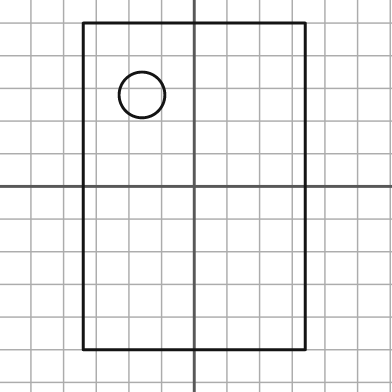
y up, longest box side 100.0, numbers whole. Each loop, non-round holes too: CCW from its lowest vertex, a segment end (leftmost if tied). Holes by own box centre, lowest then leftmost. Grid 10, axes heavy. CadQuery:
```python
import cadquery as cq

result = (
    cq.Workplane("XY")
    .moveTo(-34.0, -50.0)
    .lineTo(34.0, -50.0)
    .lineTo(34.0, 50.0)
    .lineTo(-34.0, 50.0)
    .close()
    .moveTo(-16.0, 28.0)
    .circle(7.0)
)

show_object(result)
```